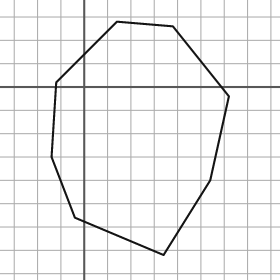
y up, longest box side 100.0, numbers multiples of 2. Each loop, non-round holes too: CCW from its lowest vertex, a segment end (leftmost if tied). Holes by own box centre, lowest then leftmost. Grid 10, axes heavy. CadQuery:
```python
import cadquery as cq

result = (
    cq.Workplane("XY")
    .moveTo(34.0, -72.0)
    .lineTo(54.0, -40.0)
    .lineTo(62.0, -4.0)
    .lineTo(38.0, 26.0)
    .lineTo(14.0, 28.0)
    .lineTo(-12.0, 2.0)
    .lineTo(-14.0, -30.0)
    .lineTo(-4.0, -56.0)
    .close()
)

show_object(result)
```